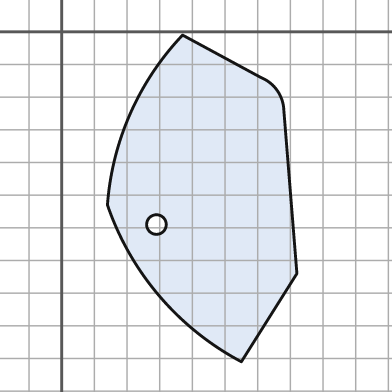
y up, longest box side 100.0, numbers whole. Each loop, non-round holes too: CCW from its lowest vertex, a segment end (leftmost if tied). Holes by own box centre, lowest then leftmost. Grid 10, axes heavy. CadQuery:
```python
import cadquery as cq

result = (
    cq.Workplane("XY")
    .moveTo(55.0, -101.0)
    .lineTo(72.0, -74.0)
    .lineTo(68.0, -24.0)
    .threePointArc((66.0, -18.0), (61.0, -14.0))
    .lineTo(37.0, -1.0)
    .threePointArc((21.0, -25.0), (14.0, -53.0))
    .threePointArc((30.0, -81.0), (55.0, -101.0))
    .close()
    .moveTo(29.0, -59.0)
    .circle(3.0)
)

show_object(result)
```